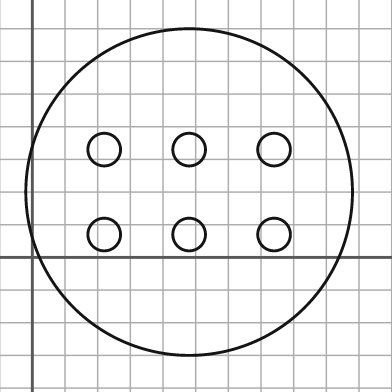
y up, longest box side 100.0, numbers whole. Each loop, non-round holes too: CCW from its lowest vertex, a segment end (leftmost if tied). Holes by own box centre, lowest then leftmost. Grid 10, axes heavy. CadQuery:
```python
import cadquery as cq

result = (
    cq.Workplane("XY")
    .moveTo(48.0, 20.0)
    .circle(50.0)
    .moveTo(22.0, 7.0)
    .circle(5.0)
    .moveTo(48.0, 7.0)
    .circle(5.0)
    .moveTo(74.0, 7.0)
    .circle(5.0)
    .moveTo(22.0, 33.0)
    .circle(5.0)
    .moveTo(48.0, 33.0)
    .circle(5.0)
    .moveTo(74.0, 33.0)
    .circle(5.0)
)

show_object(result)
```